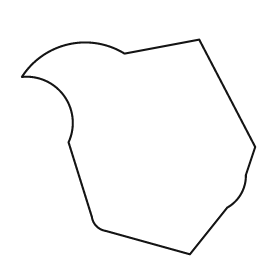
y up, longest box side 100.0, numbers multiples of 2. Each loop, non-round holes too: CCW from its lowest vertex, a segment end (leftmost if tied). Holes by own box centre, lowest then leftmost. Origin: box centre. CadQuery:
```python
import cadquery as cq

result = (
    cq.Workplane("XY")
    .moveTo(22.0, -46.0)
    .lineTo(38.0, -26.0)
    .threePointArc((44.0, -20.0), (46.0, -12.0))
    .lineTo(50.0, 0.0)
    .lineTo(26.0, 46.0)
    .lineTo(-6.0, 40.0)
    .threePointArc((-30.0, 44.0), (-50.0, 30.0))
    .threePointArc((-32.0, 22.0), (-30.0, 2.0))
    .lineTo(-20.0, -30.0)
    .threePointArc((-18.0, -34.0), (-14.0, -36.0))
    .close()
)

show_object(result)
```